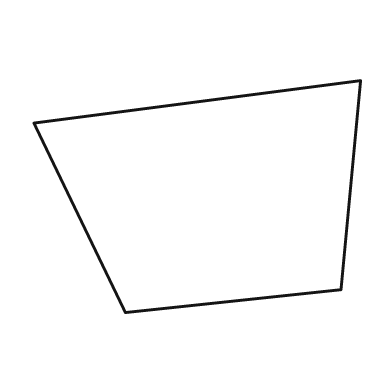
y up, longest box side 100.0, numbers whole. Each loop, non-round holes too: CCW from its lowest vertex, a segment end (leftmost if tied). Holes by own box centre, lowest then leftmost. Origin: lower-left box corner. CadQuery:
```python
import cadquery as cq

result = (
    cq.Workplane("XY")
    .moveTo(28.0, 0.0)
    .lineTo(94.0, 7.0)
    .lineTo(100.0, 71.0)
    .lineTo(0.0, 58.0)
    .close()
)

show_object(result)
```